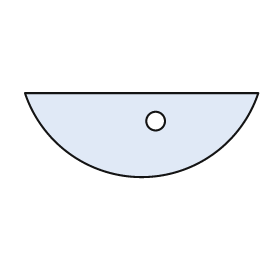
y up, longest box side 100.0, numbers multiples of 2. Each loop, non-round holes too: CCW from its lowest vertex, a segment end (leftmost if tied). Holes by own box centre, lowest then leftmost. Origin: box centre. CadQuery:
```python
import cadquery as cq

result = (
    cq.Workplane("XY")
    .moveTo(-50.0, 18.0)
    .threePointArc((0.0, -18.0), (50.0, 18.0))
    .close()
    .moveTo(6.0, 6.0)
    .circle(4.0)
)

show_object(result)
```